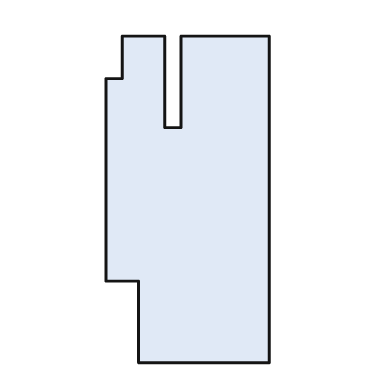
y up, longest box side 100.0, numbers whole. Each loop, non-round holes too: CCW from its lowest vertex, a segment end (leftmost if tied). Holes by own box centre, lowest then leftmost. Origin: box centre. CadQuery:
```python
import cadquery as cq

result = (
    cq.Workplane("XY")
    .moveTo(-15.0, -50.0)
    .lineTo(25.0, -50.0)
    .lineTo(25.0, 50.0)
    .lineTo(-2.0, 50.0)
    .lineTo(-2.0, 22.0)
    .lineTo(-7.0, 22.0)
    .lineTo(-7.0, 50.0)
    .lineTo(-20.0, 50.0)
    .lineTo(-20.0, 37.0)
    .lineTo(-25.0, 37.0)
    .lineTo(-25.0, -25.0)
    .lineTo(-15.0, -25.0)
    .close()
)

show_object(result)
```